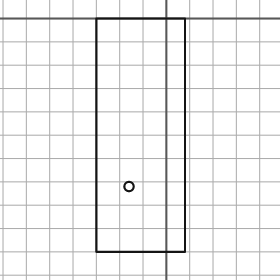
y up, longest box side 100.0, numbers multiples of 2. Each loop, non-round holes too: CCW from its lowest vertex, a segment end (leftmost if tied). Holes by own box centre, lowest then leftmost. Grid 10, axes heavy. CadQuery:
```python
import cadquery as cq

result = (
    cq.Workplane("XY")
    .moveTo(-30.0, -100.0)
    .lineTo(8.0, -100.0)
    .lineTo(8.0, 0.0)
    .lineTo(-30.0, 0.0)
    .close()
    .moveTo(-16.0, -72.0)
    .circle(2.0)
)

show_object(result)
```